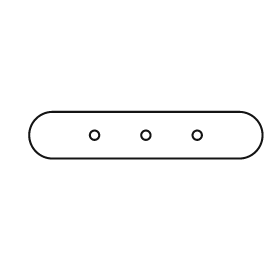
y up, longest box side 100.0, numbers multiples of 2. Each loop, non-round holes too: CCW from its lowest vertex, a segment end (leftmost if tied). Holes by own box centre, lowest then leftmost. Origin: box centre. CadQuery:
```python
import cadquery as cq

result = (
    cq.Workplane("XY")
    .moveTo(-40.0, -10.0)
    .lineTo(40.0, -10.0)
    .threePointArc((50.0, 0.0), (40.0, 10.0))
    .lineTo(-40.0, 10.0)
    .threePointArc((-50.0, 0.0), (-40.0, -10.0))
    .close()
    .moveTo(-22.0, 0.0)
    .circle(2.0)
    .moveTo(0.0, 0.0)
    .circle(2.0)
    .moveTo(22.0, 0.0)
    .circle(2.0)
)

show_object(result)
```